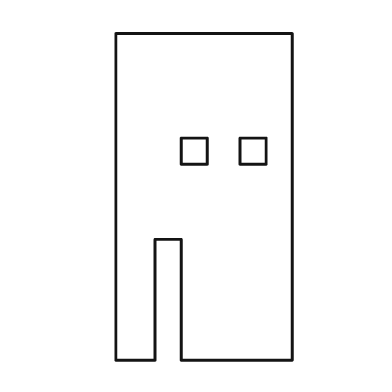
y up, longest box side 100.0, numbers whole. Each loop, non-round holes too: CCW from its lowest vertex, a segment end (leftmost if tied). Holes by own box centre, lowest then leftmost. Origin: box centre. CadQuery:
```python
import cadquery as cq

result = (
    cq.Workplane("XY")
    .moveTo(-27.0, -50.0)
    .lineTo(-15.0, -50.0)
    .lineTo(-15.0, -13.0)
    .lineTo(-7.0, -13.0)
    .lineTo(-7.0, -50.0)
    .lineTo(27.0, -50.0)
    .lineTo(27.0, 50.0)
    .lineTo(-27.0, 50.0)
    .close()
    .moveTo(-7.0, 10.0)
    .lineTo(1.0, 10.0)
    .lineTo(1.0, 18.0)
    .lineTo(-7.0, 18.0)
    .close()
    .moveTo(11.0, 10.0)
    .lineTo(19.0, 10.0)
    .lineTo(19.0, 18.0)
    .lineTo(11.0, 18.0)
    .close()
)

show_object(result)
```